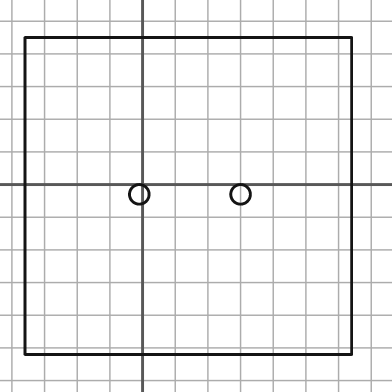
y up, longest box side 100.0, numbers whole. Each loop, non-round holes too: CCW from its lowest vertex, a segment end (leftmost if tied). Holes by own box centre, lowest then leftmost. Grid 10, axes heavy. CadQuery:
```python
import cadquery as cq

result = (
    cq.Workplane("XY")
    .moveTo(-36.0, -52.0)
    .lineTo(64.0, -52.0)
    .lineTo(64.0, 45.0)
    .lineTo(-36.0, 45.0)
    .close()
    .moveTo(-1.0, -3.0)
    .circle(3.0)
    .moveTo(30.0, -3.0)
    .circle(3.0)
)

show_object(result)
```